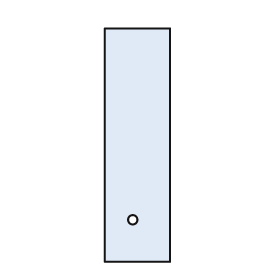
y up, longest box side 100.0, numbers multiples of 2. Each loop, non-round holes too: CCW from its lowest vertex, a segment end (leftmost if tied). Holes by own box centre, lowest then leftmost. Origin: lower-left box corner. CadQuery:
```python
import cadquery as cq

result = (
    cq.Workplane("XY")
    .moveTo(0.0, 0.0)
    .lineTo(28.0, 0.0)
    .lineTo(28.0, 100.0)
    .lineTo(0.0, 100.0)
    .close()
    .moveTo(12.0, 18.0)
    .circle(2.0)
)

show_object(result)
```